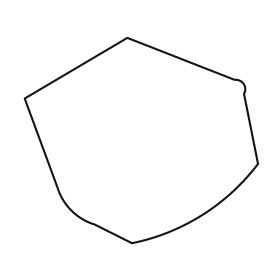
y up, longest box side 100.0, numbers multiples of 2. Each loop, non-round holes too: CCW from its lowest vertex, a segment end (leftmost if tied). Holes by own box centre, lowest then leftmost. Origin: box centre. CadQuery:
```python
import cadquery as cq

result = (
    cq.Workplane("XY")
    .moveTo(-4.0, -44.0)
    .threePointArc((26.0, -32.0), (50.0, -10.0))
    .lineTo(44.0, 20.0)
    .threePointArc((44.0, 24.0), (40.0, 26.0))
    .lineTo(-6.0, 44.0)
    .lineTo(-50.0, 18.0)
    .lineTo(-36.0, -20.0)
    .threePointArc((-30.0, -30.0), (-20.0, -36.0))
    .close()
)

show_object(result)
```